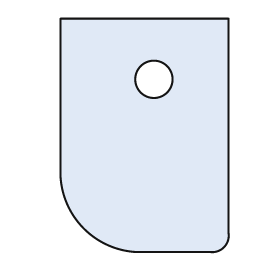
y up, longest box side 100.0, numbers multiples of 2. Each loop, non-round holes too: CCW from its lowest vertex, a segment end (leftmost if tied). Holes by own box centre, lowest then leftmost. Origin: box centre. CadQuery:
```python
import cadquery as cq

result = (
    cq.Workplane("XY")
    .moveTo(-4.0, -50.0)
    .lineTo(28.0, -50.0)
    .threePointArc((34.0, -48.0), (36.0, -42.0))
    .lineTo(36.0, 50.0)
    .lineTo(-36.0, 50.0)
    .lineTo(-36.0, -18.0)
    .threePointArc((-26.0, -40.0), (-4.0, -50.0))
    .close()
    .moveTo(4.0, 24.0)
    .circle(8.0)
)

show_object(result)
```